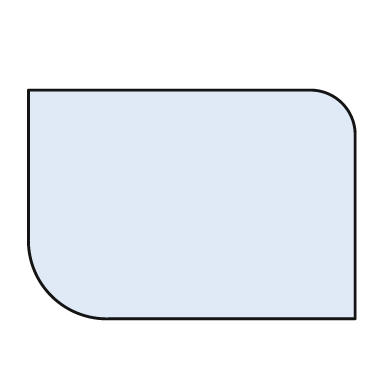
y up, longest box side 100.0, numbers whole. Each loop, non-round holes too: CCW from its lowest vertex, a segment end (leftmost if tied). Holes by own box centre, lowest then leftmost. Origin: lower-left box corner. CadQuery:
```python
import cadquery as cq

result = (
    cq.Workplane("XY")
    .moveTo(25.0, 0.0)
    .lineTo(100.0, 0.0)
    .lineTo(100.0, 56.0)
    .threePointArc((96.0, 66.0), (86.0, 70.0))
    .lineTo(0.0, 70.0)
    .lineTo(0.0, 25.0)
    .threePointArc((7.0, 7.0), (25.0, 0.0))
    .close()
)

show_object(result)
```